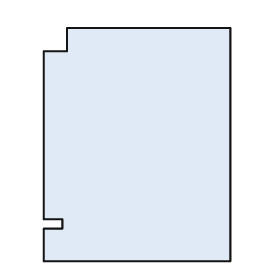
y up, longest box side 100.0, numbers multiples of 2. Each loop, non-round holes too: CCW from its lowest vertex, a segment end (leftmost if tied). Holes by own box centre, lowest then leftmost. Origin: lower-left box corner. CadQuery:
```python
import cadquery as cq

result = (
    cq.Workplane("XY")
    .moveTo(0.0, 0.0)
    .lineTo(80.0, 0.0)
    .lineTo(80.0, 100.0)
    .lineTo(10.0, 100.0)
    .lineTo(10.0, 90.0)
    .lineTo(0.0, 90.0)
    .lineTo(0.0, 18.0)
    .lineTo(8.0, 18.0)
    .lineTo(8.0, 14.0)
    .lineTo(0.0, 14.0)
    .close()
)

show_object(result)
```